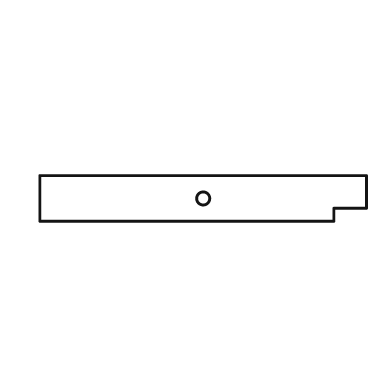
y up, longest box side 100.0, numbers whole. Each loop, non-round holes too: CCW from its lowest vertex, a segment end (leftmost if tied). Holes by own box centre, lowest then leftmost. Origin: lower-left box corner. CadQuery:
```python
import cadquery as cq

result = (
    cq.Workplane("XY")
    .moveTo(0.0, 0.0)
    .lineTo(90.0, 0.0)
    .lineTo(90.0, 4.0)
    .lineTo(100.0, 4.0)
    .lineTo(100.0, 14.0)
    .lineTo(0.0, 14.0)
    .close()
    .moveTo(50.0, 7.0)
    .circle(2.0)
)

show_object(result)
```